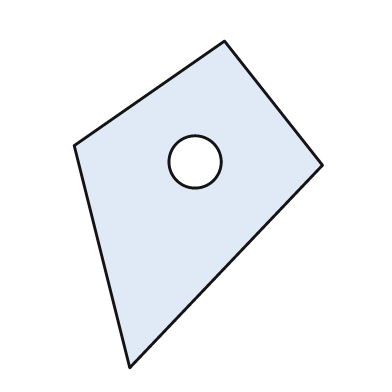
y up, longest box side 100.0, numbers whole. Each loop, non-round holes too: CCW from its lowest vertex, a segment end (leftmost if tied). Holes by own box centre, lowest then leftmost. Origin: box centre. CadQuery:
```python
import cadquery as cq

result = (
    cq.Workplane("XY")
    .moveTo(-21.0, -50.0)
    .lineTo(38.0, 12.0)
    .lineTo(8.0, 50.0)
    .lineTo(-38.0, 18.0)
    .close()
    .moveTo(-1.0, 13.0)
    .circle(8.0)
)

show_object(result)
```